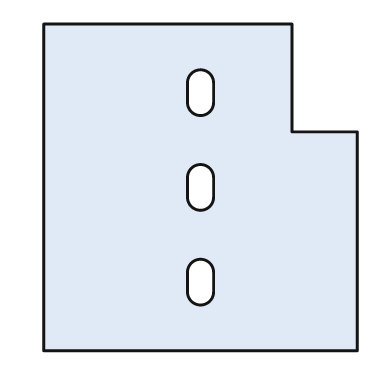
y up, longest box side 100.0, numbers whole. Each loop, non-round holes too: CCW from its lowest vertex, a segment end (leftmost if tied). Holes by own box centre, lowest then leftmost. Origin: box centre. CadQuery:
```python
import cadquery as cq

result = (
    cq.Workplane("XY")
    .moveTo(-48.0, -50.0)
    .lineTo(48.0, -50.0)
    .lineTo(48.0, 17.0)
    .lineTo(28.0, 17.0)
    .lineTo(28.0, 50.0)
    .lineTo(-48.0, 50.0)
    .close()
    .moveTo(-4.0, -32.0)
    .threePointArc((0.0, -36.0), (4.0, -32.0))
    .lineTo(4.0, -26.0)
    .threePointArc((0.0, -22.0), (-4.0, -26.0))
    .close()
    .moveTo(-4.0, -3.0)
    .threePointArc((0.0, -7.0), (4.0, -3.0))
    .lineTo(4.0, 3.0)
    .threePointArc((0.0, 7.0), (-4.0, 3.0))
    .close()
    .moveTo(-4.0, 26.0)
    .threePointArc((0.0, 22.0), (4.0, 26.0))
    .lineTo(4.0, 32.0)
    .threePointArc((0.0, 36.0), (-4.0, 32.0))
    .close()
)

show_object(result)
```